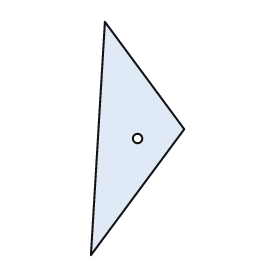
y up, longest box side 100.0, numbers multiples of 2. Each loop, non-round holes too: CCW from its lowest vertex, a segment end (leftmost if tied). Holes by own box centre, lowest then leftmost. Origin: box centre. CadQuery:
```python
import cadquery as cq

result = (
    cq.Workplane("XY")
    .moveTo(-20.0, -50.0)
    .lineTo(20.0, 4.0)
    .lineTo(-14.0, 50.0)
    .close()
    .moveTo(0.0, 0.0)
    .circle(2.0)
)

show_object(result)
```